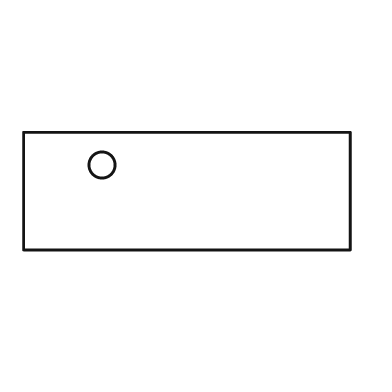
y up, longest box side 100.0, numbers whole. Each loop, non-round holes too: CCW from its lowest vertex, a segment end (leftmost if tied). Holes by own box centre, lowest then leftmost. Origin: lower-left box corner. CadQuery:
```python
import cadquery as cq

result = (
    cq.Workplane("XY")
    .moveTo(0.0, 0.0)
    .lineTo(100.0, 0.0)
    .lineTo(100.0, 36.0)
    .lineTo(0.0, 36.0)
    .close()
    .moveTo(24.0, 26.0)
    .circle(4.0)
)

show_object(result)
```